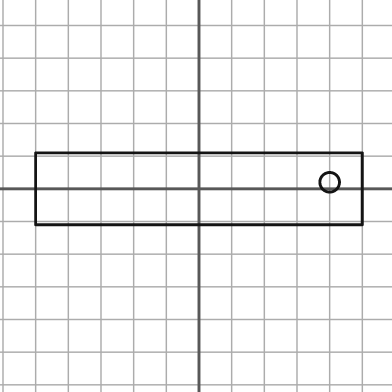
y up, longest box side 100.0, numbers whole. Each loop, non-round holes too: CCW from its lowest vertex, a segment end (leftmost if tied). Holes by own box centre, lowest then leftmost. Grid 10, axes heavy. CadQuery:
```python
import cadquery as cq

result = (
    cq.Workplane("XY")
    .moveTo(-50.0, -11.0)
    .lineTo(50.0, -11.0)
    .lineTo(50.0, 11.0)
    .lineTo(-50.0, 11.0)
    .close()
    .moveTo(40.0, 2.0)
    .circle(3.0)
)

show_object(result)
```